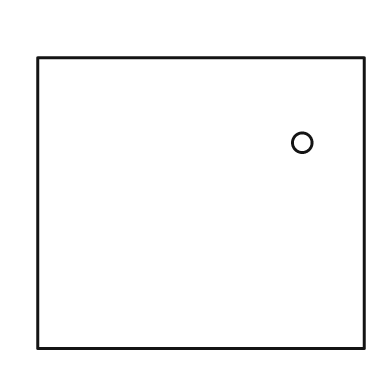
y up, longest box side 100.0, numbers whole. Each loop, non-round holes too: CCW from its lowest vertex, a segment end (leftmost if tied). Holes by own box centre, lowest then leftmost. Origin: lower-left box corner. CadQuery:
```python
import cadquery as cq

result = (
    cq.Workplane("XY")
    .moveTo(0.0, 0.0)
    .lineTo(100.0, 0.0)
    .lineTo(100.0, 89.0)
    .lineTo(0.0, 89.0)
    .close()
    .moveTo(81.0, 63.0)
    .circle(3.0)
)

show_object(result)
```